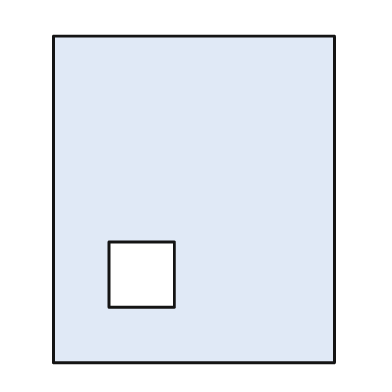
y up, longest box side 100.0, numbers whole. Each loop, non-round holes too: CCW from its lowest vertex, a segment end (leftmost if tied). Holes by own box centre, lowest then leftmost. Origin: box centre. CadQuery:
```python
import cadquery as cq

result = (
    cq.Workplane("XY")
    .moveTo(-43.0, -50.0)
    .lineTo(43.0, -50.0)
    .lineTo(43.0, 50.0)
    .lineTo(-43.0, 50.0)
    .close()
    .moveTo(-26.0, -33.0)
    .lineTo(-6.0, -33.0)
    .lineTo(-6.0, -13.0)
    .lineTo(-26.0, -13.0)
    .close()
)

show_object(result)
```